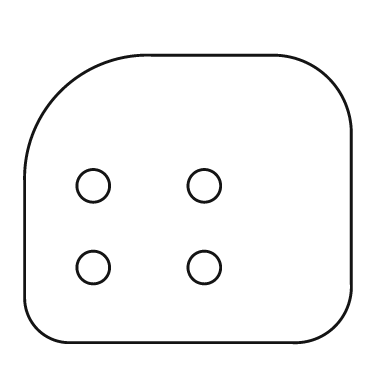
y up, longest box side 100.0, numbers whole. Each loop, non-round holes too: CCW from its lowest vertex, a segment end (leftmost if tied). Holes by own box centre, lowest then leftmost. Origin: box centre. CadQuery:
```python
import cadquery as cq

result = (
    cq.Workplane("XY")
    .moveTo(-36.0, -44.0)
    .lineTo(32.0, -44.0)
    .threePointArc((45.0, -39.0), (50.0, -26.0))
    .lineTo(50.0, 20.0)
    .threePointArc((43.0, 37.0), (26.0, 44.0))
    .lineTo(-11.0, 44.0)
    .threePointArc((-39.0, 33.0), (-50.0, 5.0))
    .lineTo(-50.0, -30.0)
    .threePointArc((-46.0, -40.0), (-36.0, -44.0))
    .close()
    .moveTo(-29.0, -21.0)
    .circle(5.0)
    .moveTo(5.0, -21.0)
    .circle(5.0)
    .moveTo(-29.0, 4.0)
    .circle(5.0)
    .moveTo(5.0, 4.0)
    .circle(5.0)
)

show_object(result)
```